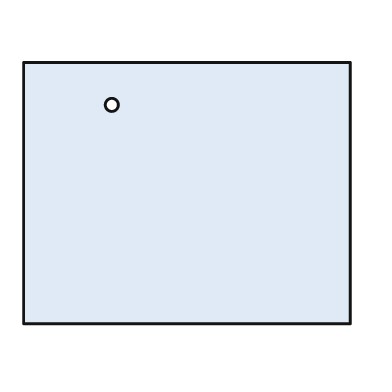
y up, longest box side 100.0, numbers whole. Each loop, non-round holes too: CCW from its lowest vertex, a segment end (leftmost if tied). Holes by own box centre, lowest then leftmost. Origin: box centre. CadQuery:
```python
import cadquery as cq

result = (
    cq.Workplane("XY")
    .moveTo(-50.0, -40.0)
    .lineTo(50.0, -40.0)
    .lineTo(50.0, 40.0)
    .lineTo(-50.0, 40.0)
    .close()
    .moveTo(-23.0, 27.0)
    .circle(2.0)
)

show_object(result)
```